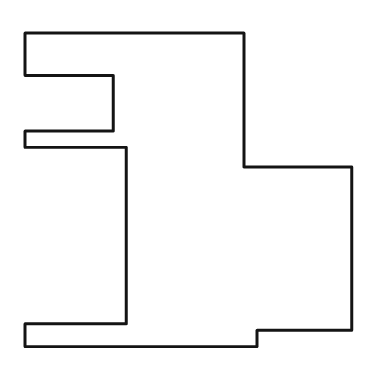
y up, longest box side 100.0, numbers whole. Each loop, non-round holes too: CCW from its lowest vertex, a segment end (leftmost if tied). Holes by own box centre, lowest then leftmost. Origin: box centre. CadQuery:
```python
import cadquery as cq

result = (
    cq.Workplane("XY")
    .moveTo(-50.0, -48.0)
    .lineTo(21.0, -48.0)
    .lineTo(21.0, -43.0)
    .lineTo(50.0, -43.0)
    .lineTo(50.0, 7.0)
    .lineTo(17.0, 7.0)
    .lineTo(17.0, 48.0)
    .lineTo(-50.0, 48.0)
    .lineTo(-50.0, 35.0)
    .lineTo(-23.0, 35.0)
    .lineTo(-23.0, 18.0)
    .lineTo(-50.0, 18.0)
    .lineTo(-50.0, 13.0)
    .lineTo(-19.0, 13.0)
    .lineTo(-19.0, -41.0)
    .lineTo(-50.0, -41.0)
    .close()
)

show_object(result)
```